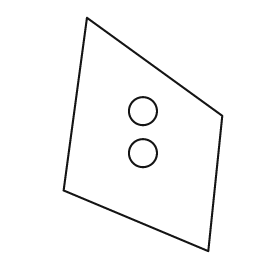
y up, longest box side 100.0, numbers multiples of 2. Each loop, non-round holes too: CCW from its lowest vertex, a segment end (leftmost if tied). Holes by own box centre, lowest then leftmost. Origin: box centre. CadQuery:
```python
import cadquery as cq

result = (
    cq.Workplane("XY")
    .moveTo(28.0, -50.0)
    .lineTo(34.0, 8.0)
    .lineTo(-24.0, 50.0)
    .lineTo(-34.0, -24.0)
    .close()
    .moveTo(0.0, -8.0)
    .circle(6.0)
    .moveTo(0.0, 10.0)
    .circle(6.0)
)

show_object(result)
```